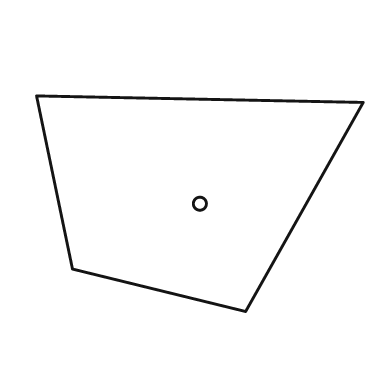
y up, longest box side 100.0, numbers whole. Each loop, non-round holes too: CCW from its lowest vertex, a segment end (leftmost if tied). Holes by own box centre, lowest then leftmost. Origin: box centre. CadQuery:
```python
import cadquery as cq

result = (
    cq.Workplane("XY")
    .moveTo(14.0, -33.0)
    .lineTo(50.0, 31.0)
    .lineTo(-50.0, 33.0)
    .lineTo(-39.0, -20.0)
    .close()
    .moveTo(0.0, 0.0)
    .circle(2.0)
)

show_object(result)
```